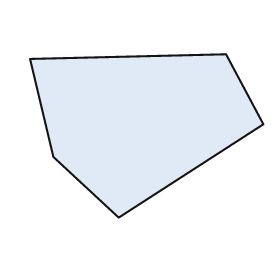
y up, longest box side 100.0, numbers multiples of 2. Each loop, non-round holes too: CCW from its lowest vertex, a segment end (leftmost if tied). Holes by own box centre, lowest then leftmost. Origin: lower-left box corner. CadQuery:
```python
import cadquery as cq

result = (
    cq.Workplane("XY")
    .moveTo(38.0, 0.0)
    .lineTo(100.0, 40.0)
    .lineTo(84.0, 70.0)
    .lineTo(0.0, 68.0)
    .lineTo(10.0, 26.0)
    .close()
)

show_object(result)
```